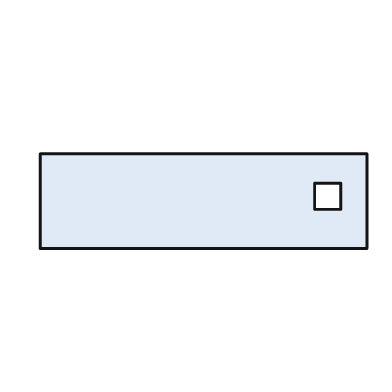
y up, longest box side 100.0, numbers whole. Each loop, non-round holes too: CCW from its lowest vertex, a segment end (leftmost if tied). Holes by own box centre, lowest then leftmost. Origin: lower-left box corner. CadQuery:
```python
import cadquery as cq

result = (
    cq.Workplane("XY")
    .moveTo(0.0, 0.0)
    .lineTo(100.0, 0.0)
    .lineTo(100.0, 29.0)
    .lineTo(0.0, 29.0)
    .close()
    .moveTo(84.0, 12.0)
    .lineTo(92.0, 12.0)
    .lineTo(92.0, 20.0)
    .lineTo(84.0, 20.0)
    .close()
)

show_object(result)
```